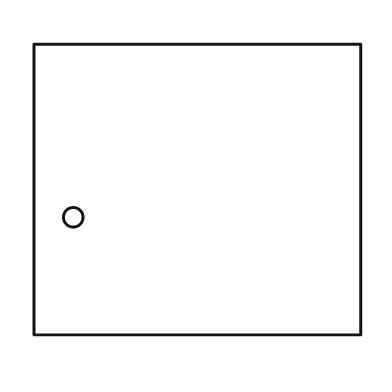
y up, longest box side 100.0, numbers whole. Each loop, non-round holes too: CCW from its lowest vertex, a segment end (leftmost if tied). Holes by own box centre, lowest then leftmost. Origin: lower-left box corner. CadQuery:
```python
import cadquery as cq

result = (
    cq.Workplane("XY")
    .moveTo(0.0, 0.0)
    .lineTo(100.0, 0.0)
    .lineTo(100.0, 89.0)
    .lineTo(0.0, 89.0)
    .close()
    .moveTo(12.0, 36.0)
    .circle(3.0)
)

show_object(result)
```